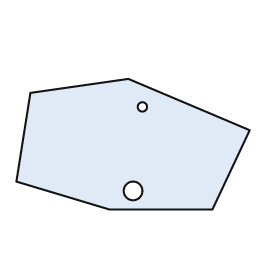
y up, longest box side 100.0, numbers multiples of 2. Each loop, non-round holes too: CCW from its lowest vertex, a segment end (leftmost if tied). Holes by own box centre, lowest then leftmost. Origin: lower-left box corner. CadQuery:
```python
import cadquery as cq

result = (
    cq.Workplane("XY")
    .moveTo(40.0, 0.0)
    .lineTo(84.0, 0.0)
    .lineTo(100.0, 34.0)
    .lineTo(48.0, 56.0)
    .lineTo(6.0, 50.0)
    .lineTo(0.0, 12.0)
    .close()
    .moveTo(50.0, 8.0)
    .circle(4.0)
    .moveTo(54.0, 44.0)
    .circle(2.0)
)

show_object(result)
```